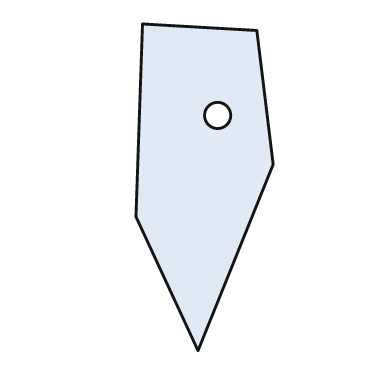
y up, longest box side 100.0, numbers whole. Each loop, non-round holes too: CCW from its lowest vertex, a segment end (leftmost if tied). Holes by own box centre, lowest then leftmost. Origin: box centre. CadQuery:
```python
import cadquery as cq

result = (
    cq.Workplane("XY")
    .moveTo(-2.0, -50.0)
    .lineTo(21.0, 7.0)
    .lineTo(16.0, 48.0)
    .lineTo(-19.0, 50.0)
    .lineTo(-21.0, -9.0)
    .close()
    .moveTo(4.0, 22.0)
    .circle(4.0)
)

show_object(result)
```